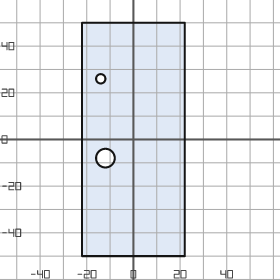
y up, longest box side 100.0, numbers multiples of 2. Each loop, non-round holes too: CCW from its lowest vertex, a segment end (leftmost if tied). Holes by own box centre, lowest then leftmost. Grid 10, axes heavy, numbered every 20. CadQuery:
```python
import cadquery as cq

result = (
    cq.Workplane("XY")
    .moveTo(-22.0, -50.0)
    .lineTo(22.0, -50.0)
    .lineTo(22.0, 50.0)
    .lineTo(-22.0, 50.0)
    .close()
    .moveTo(-12.0, -8.0)
    .circle(4.0)
    .moveTo(-14.0, 26.0)
    .circle(2.0)
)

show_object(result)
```